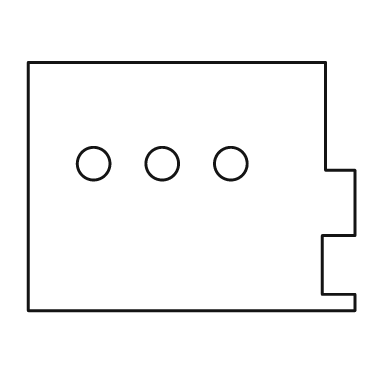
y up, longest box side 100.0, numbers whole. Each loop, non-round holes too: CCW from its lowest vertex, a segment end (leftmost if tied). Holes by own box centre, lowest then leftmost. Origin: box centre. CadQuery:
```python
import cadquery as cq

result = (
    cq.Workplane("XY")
    .moveTo(-50.0, -38.0)
    .lineTo(50.0, -38.0)
    .lineTo(50.0, -33.0)
    .lineTo(40.0, -33.0)
    .lineTo(40.0, -15.0)
    .lineTo(50.0, -15.0)
    .lineTo(50.0, 5.0)
    .lineTo(41.0, 5.0)
    .lineTo(41.0, 38.0)
    .lineTo(-50.0, 38.0)
    .close()
    .moveTo(-30.0, 7.0)
    .circle(5.0)
    .moveTo(-9.0, 7.0)
    .circle(5.0)
    .moveTo(12.0, 7.0)
    .circle(5.0)
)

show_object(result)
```